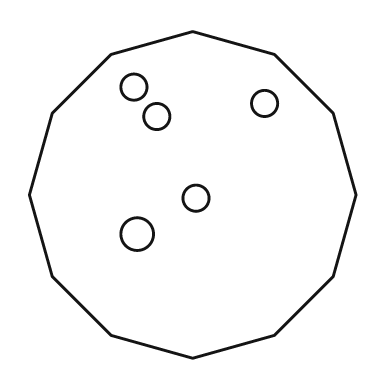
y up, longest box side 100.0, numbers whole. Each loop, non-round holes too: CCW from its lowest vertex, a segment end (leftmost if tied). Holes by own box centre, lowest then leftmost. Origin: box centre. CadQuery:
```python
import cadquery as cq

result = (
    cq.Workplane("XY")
    .moveTo(0.0, -50.0)
    .lineTo(25.0, -43.0)
    .lineTo(43.0, -25.0)
    .lineTo(50.0, 0.0)
    .lineTo(43.0, 25.0)
    .lineTo(25.0, 43.0)
    .lineTo(0.0, 50.0)
    .lineTo(-25.0, 43.0)
    .lineTo(-43.0, 25.0)
    .lineTo(-50.0, 0.0)
    .lineTo(-43.0, -25.0)
    .lineTo(-25.0, -43.0)
    .close()
    .moveTo(-17.0, -12.0)
    .circle(5.0)
    .moveTo(1.0, -1.0)
    .circle(4.0)
    .moveTo(-11.0, 24.0)
    .circle(4.0)
    .moveTo(22.0, 28.0)
    .circle(4.0)
    .moveTo(-18.0, 33.0)
    .circle(4.0)
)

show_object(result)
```